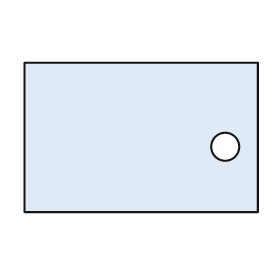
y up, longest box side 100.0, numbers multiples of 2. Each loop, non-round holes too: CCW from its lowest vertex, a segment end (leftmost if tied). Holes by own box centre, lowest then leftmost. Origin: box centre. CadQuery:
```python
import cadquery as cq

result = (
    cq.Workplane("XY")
    .moveTo(-50.0, -32.0)
    .lineTo(50.0, -32.0)
    .lineTo(50.0, 32.0)
    .lineTo(-50.0, 32.0)
    .close()
    .moveTo(36.0, -4.0)
    .circle(6.0)
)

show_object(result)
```